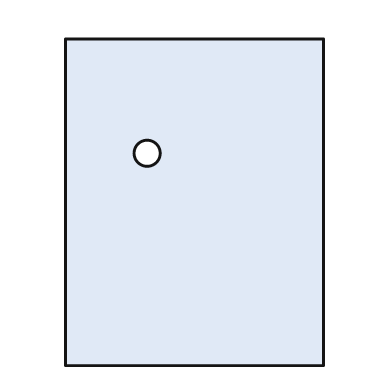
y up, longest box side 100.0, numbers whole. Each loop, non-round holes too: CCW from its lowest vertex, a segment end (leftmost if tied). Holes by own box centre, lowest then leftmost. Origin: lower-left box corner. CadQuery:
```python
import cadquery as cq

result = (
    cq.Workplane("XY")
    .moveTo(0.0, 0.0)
    .lineTo(79.0, 0.0)
    .lineTo(79.0, 100.0)
    .lineTo(0.0, 100.0)
    .close()
    .moveTo(25.0, 65.0)
    .circle(4.0)
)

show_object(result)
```